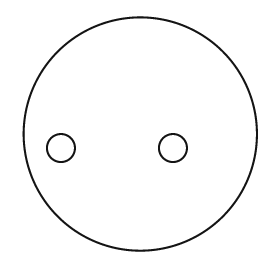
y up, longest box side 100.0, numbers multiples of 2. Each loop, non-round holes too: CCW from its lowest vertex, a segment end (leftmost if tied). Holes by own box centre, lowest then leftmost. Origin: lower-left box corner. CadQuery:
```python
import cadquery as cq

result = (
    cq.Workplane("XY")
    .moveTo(50.0, 50.0)
    .circle(50.0)
    .moveTo(16.0, 44.0)
    .circle(6.0)
    .moveTo(64.0, 44.0)
    .circle(6.0)
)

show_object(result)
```